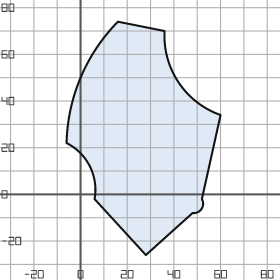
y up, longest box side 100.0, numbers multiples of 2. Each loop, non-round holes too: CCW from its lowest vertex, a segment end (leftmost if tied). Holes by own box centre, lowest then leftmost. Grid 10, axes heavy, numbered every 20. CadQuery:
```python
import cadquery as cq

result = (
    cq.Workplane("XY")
    .moveTo(28.0, -26.0)
    .lineTo(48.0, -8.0)
    .threePointArc((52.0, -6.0), (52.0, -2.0))
    .lineTo(60.0, 34.0)
    .threePointArc((42.0, 48.0), (36.0, 70.0))
    .lineTo(16.0, 74.0)
    .threePointArc((0.0, 50.0), (-6.0, 22.0))
    .threePointArc((4.0, 12.0), (6.0, -2.0))
    .close()
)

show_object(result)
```